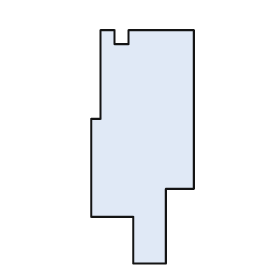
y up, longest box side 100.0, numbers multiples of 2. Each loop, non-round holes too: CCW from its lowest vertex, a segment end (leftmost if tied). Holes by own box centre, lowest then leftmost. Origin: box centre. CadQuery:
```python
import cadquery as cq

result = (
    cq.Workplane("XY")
    .moveTo(-4.0, -50.0)
    .lineTo(10.0, -50.0)
    .lineTo(10.0, -18.0)
    .lineTo(22.0, -18.0)
    .lineTo(22.0, 50.0)
    .lineTo(-6.0, 50.0)
    .lineTo(-6.0, 44.0)
    .lineTo(-12.0, 44.0)
    .lineTo(-12.0, 50.0)
    .lineTo(-18.0, 50.0)
    .lineTo(-18.0, 12.0)
    .lineTo(-22.0, 12.0)
    .lineTo(-22.0, -30.0)
    .lineTo(-4.0, -30.0)
    .close()
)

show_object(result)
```